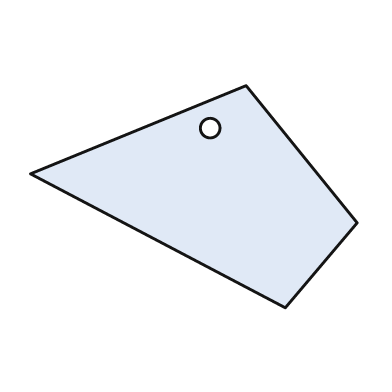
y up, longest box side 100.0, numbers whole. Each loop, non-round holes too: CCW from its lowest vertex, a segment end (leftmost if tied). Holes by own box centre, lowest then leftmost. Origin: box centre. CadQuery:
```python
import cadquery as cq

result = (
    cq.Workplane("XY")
    .moveTo(28.0, -34.0)
    .lineTo(50.0, -8.0)
    .lineTo(16.0, 34.0)
    .lineTo(-50.0, 7.0)
    .close()
    .moveTo(5.0, 21.0)
    .circle(3.0)
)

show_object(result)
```